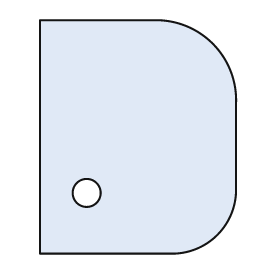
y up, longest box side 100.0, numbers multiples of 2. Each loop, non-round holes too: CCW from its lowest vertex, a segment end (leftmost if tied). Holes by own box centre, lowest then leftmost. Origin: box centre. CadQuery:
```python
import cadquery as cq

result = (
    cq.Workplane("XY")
    .moveTo(-42.0, -50.0)
    .lineTo(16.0, -50.0)
    .threePointArc((34.0, -42.0), (42.0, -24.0))
    .lineTo(42.0, 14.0)
    .threePointArc((32.0, 40.0), (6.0, 50.0))
    .lineTo(-42.0, 50.0)
    .close()
    .moveTo(-22.0, -24.0)
    .circle(6.0)
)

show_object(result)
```